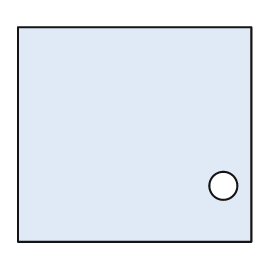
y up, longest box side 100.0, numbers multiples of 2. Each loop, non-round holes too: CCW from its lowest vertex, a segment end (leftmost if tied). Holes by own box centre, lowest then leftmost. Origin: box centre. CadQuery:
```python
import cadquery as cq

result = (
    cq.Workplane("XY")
    .moveTo(-50.0, -46.0)
    .lineTo(50.0, -46.0)
    .lineTo(50.0, 46.0)
    .lineTo(-50.0, 46.0)
    .close()
    .moveTo(38.0, -22.0)
    .circle(6.0)
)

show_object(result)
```